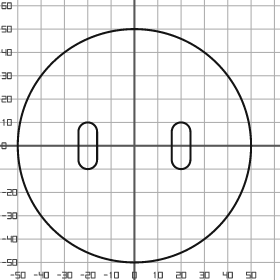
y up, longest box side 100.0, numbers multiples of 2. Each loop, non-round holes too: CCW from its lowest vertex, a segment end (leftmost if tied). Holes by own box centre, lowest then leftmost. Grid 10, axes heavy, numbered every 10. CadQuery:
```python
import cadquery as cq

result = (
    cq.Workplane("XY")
    .moveTo(0.0, 0.0)
    .circle(50.0)
    .moveTo(-24.0, -6.0)
    .threePointArc((-20.0, -10.0), (-16.0, -6.0))
    .lineTo(-16.0, 6.0)
    .threePointArc((-20.0, 10.0), (-24.0, 6.0))
    .close()
    .moveTo(16.0, -6.0)
    .threePointArc((20.0, -10.0), (24.0, -6.0))
    .lineTo(24.0, 6.0)
    .threePointArc((20.0, 10.0), (16.0, 6.0))
    .close()
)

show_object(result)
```